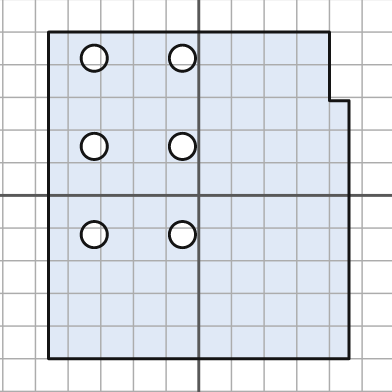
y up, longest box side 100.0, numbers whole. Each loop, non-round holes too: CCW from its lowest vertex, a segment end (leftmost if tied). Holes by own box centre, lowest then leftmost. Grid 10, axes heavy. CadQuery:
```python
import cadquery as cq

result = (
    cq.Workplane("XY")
    .moveTo(-46.0, -50.0)
    .lineTo(46.0, -50.0)
    .lineTo(46.0, 29.0)
    .lineTo(40.0, 29.0)
    .lineTo(40.0, 50.0)
    .lineTo(-46.0, 50.0)
    .close()
    .moveTo(-32.0, -12.0)
    .circle(4.0)
    .moveTo(-5.0, -12.0)
    .circle(4.0)
    .moveTo(-32.0, 15.0)
    .circle(4.0)
    .moveTo(-5.0, 15.0)
    .circle(4.0)
    .moveTo(-32.0, 42.0)
    .circle(4.0)
    .moveTo(-5.0, 42.0)
    .circle(4.0)
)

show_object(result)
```